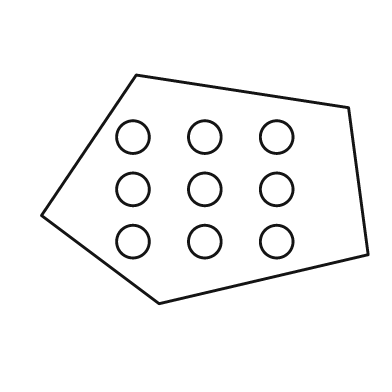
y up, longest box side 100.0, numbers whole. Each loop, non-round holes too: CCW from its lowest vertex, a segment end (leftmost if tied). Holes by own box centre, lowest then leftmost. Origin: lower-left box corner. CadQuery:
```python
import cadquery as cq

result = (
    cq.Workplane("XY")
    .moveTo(36.0, 0.0)
    .lineTo(100.0, 15.0)
    .lineTo(94.0, 60.0)
    .lineTo(29.0, 70.0)
    .lineTo(0.0, 27.0)
    .close()
    .moveTo(28.0, 19.0)
    .circle(5.0)
    .moveTo(50.0, 19.0)
    .circle(5.0)
    .moveTo(72.0, 19.0)
    .circle(5.0)
    .moveTo(28.0, 35.0)
    .circle(5.0)
    .moveTo(50.0, 35.0)
    .circle(5.0)
    .moveTo(72.0, 35.0)
    .circle(5.0)
    .moveTo(28.0, 51.0)
    .circle(5.0)
    .moveTo(50.0, 51.0)
    .circle(5.0)
    .moveTo(72.0, 51.0)
    .circle(5.0)
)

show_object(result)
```